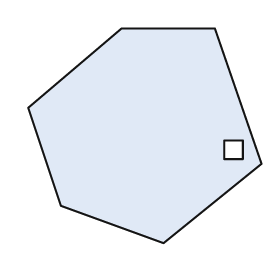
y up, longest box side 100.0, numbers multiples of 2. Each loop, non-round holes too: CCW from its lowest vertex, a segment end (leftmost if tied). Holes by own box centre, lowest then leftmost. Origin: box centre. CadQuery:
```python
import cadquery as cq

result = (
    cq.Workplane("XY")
    .moveTo(8.0, -46.0)
    .lineTo(50.0, -12.0)
    .lineTo(30.0, 46.0)
    .lineTo(-10.0, 46.0)
    .lineTo(-50.0, 12.0)
    .lineTo(-36.0, -30.0)
    .close()
    .moveTo(34.0, -10.0)
    .lineTo(42.0, -10.0)
    .lineTo(42.0, -2.0)
    .lineTo(34.0, -2.0)
    .close()
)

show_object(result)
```